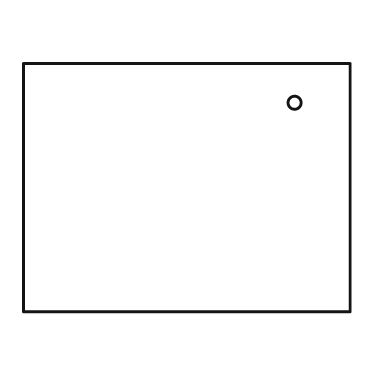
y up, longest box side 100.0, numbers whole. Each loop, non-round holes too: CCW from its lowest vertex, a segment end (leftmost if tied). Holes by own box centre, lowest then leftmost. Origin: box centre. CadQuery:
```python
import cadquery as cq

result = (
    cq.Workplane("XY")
    .moveTo(-50.0, -38.0)
    .lineTo(50.0, -38.0)
    .lineTo(50.0, 38.0)
    .lineTo(-50.0, 38.0)
    .close()
    .moveTo(33.0, 26.0)
    .circle(2.0)
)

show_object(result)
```